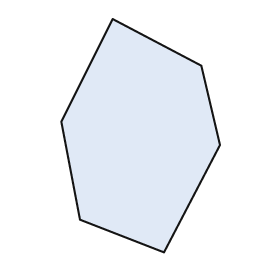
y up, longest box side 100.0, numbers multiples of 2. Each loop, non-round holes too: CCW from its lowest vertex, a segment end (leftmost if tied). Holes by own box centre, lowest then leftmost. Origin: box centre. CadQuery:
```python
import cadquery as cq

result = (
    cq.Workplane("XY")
    .moveTo(10.0, -50.0)
    .lineTo(34.0, -4.0)
    .lineTo(26.0, 30.0)
    .lineTo(-12.0, 50.0)
    .lineTo(-34.0, 6.0)
    .lineTo(-26.0, -36.0)
    .close()
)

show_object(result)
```